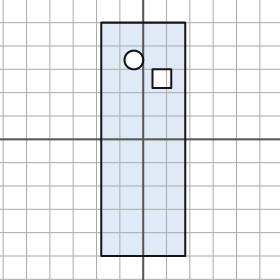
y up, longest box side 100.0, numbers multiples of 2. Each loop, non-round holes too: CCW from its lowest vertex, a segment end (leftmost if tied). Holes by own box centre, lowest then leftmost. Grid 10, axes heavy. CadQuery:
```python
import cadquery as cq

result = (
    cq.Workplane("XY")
    .moveTo(-18.0, -50.0)
    .lineTo(18.0, -50.0)
    .lineTo(18.0, 50.0)
    .lineTo(-18.0, 50.0)
    .close()
    .moveTo(4.0, 22.0)
    .lineTo(12.0, 22.0)
    .lineTo(12.0, 30.0)
    .lineTo(4.0, 30.0)
    .close()
    .moveTo(-4.0, 34.0)
    .circle(4.0)
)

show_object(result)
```